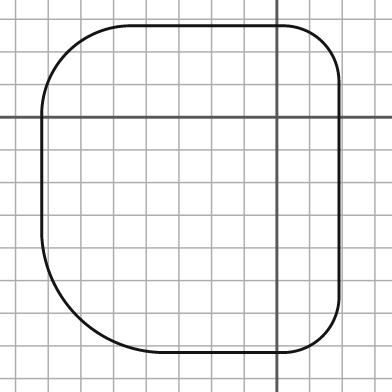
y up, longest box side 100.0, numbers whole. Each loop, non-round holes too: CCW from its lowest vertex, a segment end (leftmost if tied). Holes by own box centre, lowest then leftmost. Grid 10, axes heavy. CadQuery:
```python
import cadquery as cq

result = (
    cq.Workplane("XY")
    .moveTo(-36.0, -72.0)
    .lineTo(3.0, -72.0)
    .threePointArc((14.0, -67.0), (19.0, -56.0))
    .lineTo(19.0, 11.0)
    .threePointArc((14.0, 23.0), (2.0, 28.0))
    .lineTo(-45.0, 28.0)
    .threePointArc((-64.0, 20.0), (-72.0, 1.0))
    .lineTo(-72.0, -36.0)
    .threePointArc((-61.0, -61.0), (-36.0, -72.0))
    .close()
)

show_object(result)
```